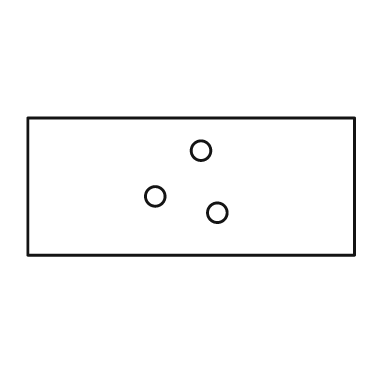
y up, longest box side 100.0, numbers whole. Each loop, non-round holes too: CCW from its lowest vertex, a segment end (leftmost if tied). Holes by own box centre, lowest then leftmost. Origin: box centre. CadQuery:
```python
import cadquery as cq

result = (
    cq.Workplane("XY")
    .moveTo(-50.0, -21.0)
    .lineTo(50.0, -21.0)
    .lineTo(50.0, 21.0)
    .lineTo(-50.0, 21.0)
    .close()
    .moveTo(8.0, -8.0)
    .circle(3.0)
    .moveTo(-11.0, -3.0)
    .circle(3.0)
    .moveTo(3.0, 11.0)
    .circle(3.0)
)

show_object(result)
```